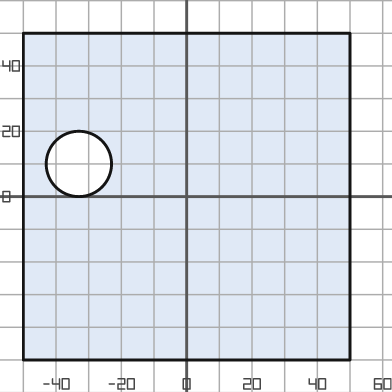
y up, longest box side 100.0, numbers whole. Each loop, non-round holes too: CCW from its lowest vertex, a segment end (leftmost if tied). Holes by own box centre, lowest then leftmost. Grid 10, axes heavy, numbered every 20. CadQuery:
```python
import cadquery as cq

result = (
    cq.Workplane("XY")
    .moveTo(-50.0, -50.0)
    .lineTo(50.0, -50.0)
    .lineTo(50.0, 50.0)
    .lineTo(-50.0, 50.0)
    .close()
    .moveTo(-33.0, 10.0)
    .circle(10.0)
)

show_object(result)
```